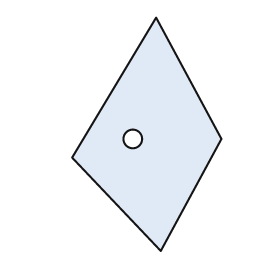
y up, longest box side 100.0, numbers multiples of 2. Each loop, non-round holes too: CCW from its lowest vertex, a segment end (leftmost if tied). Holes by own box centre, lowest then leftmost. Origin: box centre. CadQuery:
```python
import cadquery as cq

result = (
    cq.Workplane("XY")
    .moveTo(6.0, -50.0)
    .lineTo(32.0, -2.0)
    .lineTo(4.0, 50.0)
    .lineTo(-32.0, -10.0)
    .close()
    .moveTo(-6.0, -2.0)
    .circle(4.0)
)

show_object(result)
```